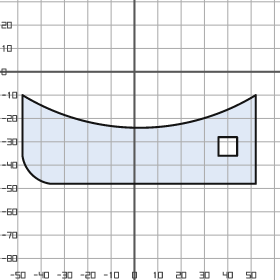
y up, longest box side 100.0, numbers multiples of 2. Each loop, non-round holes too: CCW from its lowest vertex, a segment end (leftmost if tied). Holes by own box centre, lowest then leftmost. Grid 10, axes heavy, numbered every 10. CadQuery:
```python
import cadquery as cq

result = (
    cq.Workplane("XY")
    .moveTo(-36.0, -48.0)
    .lineTo(52.0, -48.0)
    .lineTo(52.0, -10.0)
    .threePointArc((2.0, -24.0), (-48.0, -10.0))
    .lineTo(-48.0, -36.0)
    .threePointArc((-44.0, -44.0), (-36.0, -48.0))
    .close()
    .moveTo(36.0, -36.0)
    .lineTo(44.0, -36.0)
    .lineTo(44.0, -28.0)
    .lineTo(36.0, -28.0)
    .close()
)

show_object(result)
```